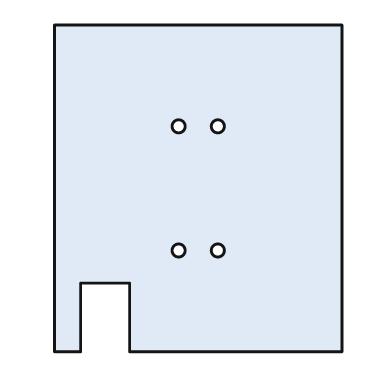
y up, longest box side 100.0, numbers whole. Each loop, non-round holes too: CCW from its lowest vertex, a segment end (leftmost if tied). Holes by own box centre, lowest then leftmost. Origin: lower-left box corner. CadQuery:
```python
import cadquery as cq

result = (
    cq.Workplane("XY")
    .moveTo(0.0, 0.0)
    .lineTo(8.0, 0.0)
    .lineTo(8.0, 21.0)
    .lineTo(23.0, 21.0)
    .lineTo(23.0, 0.0)
    .lineTo(88.0, 0.0)
    .lineTo(88.0, 100.0)
    .lineTo(0.0, 100.0)
    .close()
    .moveTo(38.0, 31.0)
    .circle(2.0)
    .moveTo(50.0, 31.0)
    .circle(2.0)
    .moveTo(38.0, 69.0)
    .circle(2.0)
    .moveTo(50.0, 69.0)
    .circle(2.0)
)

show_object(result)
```